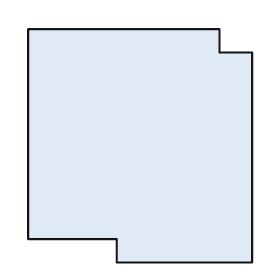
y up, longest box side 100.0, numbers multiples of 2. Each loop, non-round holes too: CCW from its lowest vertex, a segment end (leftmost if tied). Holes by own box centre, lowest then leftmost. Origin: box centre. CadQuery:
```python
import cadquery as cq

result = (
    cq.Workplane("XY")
    .moveTo(-10.0, -50.0)
    .lineTo(48.0, -50.0)
    .lineTo(48.0, 40.0)
    .lineTo(34.0, 40.0)
    .lineTo(34.0, 50.0)
    .lineTo(-48.0, 50.0)
    .lineTo(-48.0, -40.0)
    .lineTo(-10.0, -40.0)
    .close()
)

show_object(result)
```